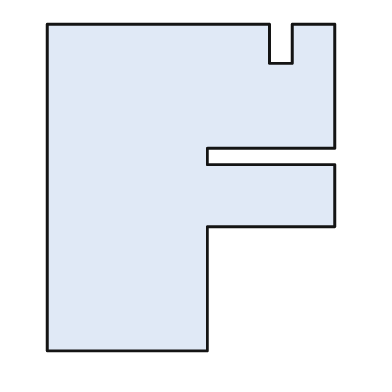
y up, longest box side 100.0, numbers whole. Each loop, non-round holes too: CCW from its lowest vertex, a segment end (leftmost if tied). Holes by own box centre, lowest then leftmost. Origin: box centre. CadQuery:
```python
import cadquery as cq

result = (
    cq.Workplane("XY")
    .moveTo(-44.0, -50.0)
    .lineTo(5.0, -50.0)
    .lineTo(5.0, -12.0)
    .lineTo(44.0, -12.0)
    .lineTo(44.0, 7.0)
    .lineTo(5.0, 7.0)
    .lineTo(5.0, 12.0)
    .lineTo(44.0, 12.0)
    .lineTo(44.0, 50.0)
    .lineTo(31.0, 50.0)
    .lineTo(31.0, 38.0)
    .lineTo(24.0, 38.0)
    .lineTo(24.0, 50.0)
    .lineTo(-44.0, 50.0)
    .close()
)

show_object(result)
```